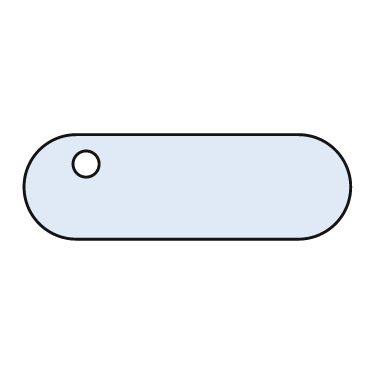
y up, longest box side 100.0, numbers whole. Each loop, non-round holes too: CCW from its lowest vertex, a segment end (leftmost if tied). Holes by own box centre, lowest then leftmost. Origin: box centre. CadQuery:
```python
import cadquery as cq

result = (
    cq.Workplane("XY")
    .moveTo(-34.0, -16.0)
    .lineTo(34.0, -16.0)
    .threePointArc((50.0, 0.0), (34.0, 16.0))
    .lineTo(-34.0, 16.0)
    .threePointArc((-50.0, 0.0), (-34.0, -16.0))
    .close()
    .moveTo(-31.0, 7.0)
    .circle(4.0)
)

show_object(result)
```